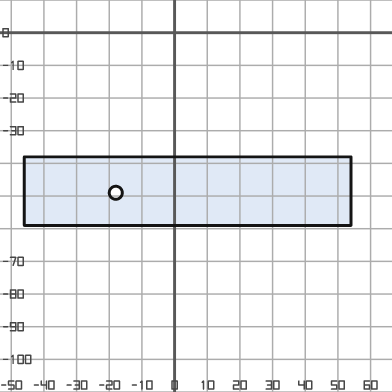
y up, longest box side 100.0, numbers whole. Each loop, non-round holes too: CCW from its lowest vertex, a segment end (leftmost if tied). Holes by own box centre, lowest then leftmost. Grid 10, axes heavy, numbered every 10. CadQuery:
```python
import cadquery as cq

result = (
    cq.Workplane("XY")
    .moveTo(-46.0, -59.0)
    .lineTo(54.0, -59.0)
    .lineTo(54.0, -38.0)
    .lineTo(-46.0, -38.0)
    .close()
    .moveTo(-18.0, -49.0)
    .circle(2.0)
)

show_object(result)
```